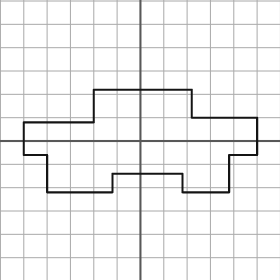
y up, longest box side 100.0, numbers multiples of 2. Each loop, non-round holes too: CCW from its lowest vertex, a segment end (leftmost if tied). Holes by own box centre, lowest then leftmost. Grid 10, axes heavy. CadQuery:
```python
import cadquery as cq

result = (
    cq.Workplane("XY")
    .moveTo(-40.0, -22.0)
    .lineTo(-12.0, -22.0)
    .lineTo(-12.0, -14.0)
    .lineTo(18.0, -14.0)
    .lineTo(18.0, -22.0)
    .lineTo(38.0, -22.0)
    .lineTo(38.0, -6.0)
    .lineTo(50.0, -6.0)
    .lineTo(50.0, 10.0)
    .lineTo(22.0, 10.0)
    .lineTo(22.0, 22.0)
    .lineTo(-20.0, 22.0)
    .lineTo(-20.0, 8.0)
    .lineTo(-50.0, 8.0)
    .lineTo(-50.0, -6.0)
    .lineTo(-40.0, -6.0)
    .close()
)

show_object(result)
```